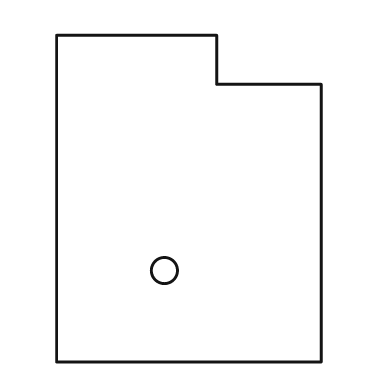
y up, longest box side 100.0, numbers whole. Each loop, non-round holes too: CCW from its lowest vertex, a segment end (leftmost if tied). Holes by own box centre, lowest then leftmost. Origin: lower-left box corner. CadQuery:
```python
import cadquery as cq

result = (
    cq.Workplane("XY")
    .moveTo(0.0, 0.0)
    .lineTo(81.0, 0.0)
    .lineTo(81.0, 85.0)
    .lineTo(49.0, 85.0)
    .lineTo(49.0, 100.0)
    .lineTo(0.0, 100.0)
    .close()
    .moveTo(33.0, 28.0)
    .circle(4.0)
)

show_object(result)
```